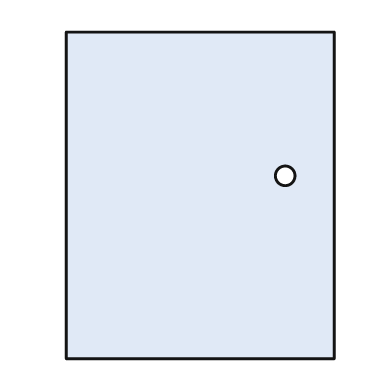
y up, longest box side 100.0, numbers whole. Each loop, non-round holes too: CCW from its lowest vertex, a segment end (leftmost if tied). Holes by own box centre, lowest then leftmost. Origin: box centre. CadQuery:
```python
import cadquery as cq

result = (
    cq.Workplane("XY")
    .moveTo(-41.0, -50.0)
    .lineTo(41.0, -50.0)
    .lineTo(41.0, 50.0)
    .lineTo(-41.0, 50.0)
    .close()
    .moveTo(26.0, 6.0)
    .circle(3.0)
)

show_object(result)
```